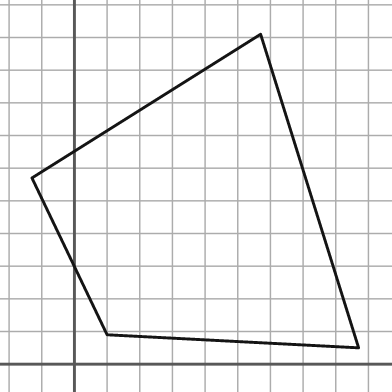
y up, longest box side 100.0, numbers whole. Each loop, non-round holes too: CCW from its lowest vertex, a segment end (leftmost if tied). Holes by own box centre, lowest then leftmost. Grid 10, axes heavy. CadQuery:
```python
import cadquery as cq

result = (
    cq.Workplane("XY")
    .moveTo(87.0, 5.0)
    .lineTo(57.0, 101.0)
    .lineTo(-13.0, 57.0)
    .lineTo(10.0, 9.0)
    .close()
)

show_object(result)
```